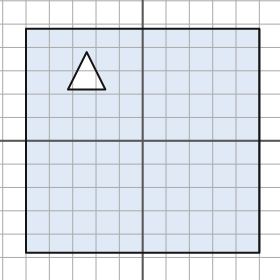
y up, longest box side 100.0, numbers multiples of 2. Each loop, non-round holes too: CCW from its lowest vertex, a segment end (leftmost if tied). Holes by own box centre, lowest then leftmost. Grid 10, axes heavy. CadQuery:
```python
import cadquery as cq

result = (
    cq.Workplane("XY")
    .moveTo(-50.0, -48.0)
    .lineTo(50.0, -48.0)
    .lineTo(50.0, 48.0)
    .lineTo(-50.0, 48.0)
    .close()
    .moveTo(-32.0, 22.0)
    .lineTo(-16.0, 22.0)
    .lineTo(-24.0, 38.0)
    .close()
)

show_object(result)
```